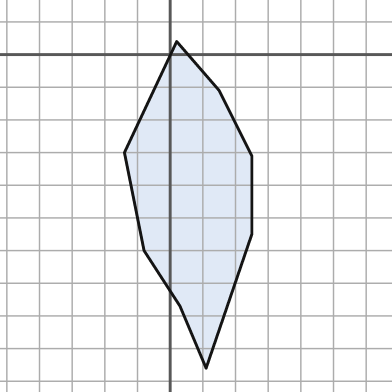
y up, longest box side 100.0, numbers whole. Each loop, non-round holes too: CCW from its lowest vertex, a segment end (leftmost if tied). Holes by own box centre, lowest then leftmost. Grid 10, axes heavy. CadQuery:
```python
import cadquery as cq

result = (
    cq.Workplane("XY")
    .moveTo(11.0, -96.0)
    .lineTo(25.0, -55.0)
    .lineTo(25.0, -31.0)
    .lineTo(15.0, -11.0)
    .lineTo(2.0, 4.0)
    .lineTo(-14.0, -30.0)
    .lineTo(-8.0, -60.0)
    .lineTo(3.0, -77.0)
    .close()
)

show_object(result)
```